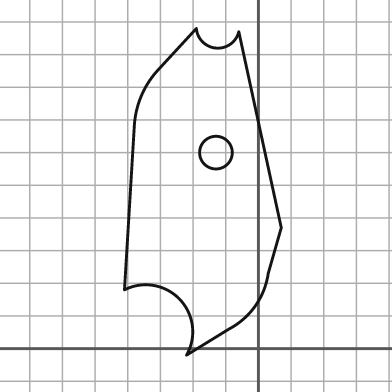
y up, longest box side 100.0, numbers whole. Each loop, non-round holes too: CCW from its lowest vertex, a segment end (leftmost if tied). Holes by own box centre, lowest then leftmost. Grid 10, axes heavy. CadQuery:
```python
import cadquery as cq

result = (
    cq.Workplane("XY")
    .moveTo(-22.0, -2.0)
    .lineTo(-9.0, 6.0)
    .threePointArc((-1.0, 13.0), (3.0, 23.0))
    .lineTo(7.0, 37.0)
    .lineTo(-6.0, 97.0)
    .threePointArc((-13.0, 92.0), (-19.0, 98.0))
    .lineTo(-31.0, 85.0)
    .threePointArc((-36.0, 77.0), (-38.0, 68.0))
    .lineTo(-41.0, 18.0)
    .threePointArc((-24.0, 15.0), (-22.0, -2.0))
    .close()
    .moveTo(-13.0, 60.0)
    .circle(5.0)
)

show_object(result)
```